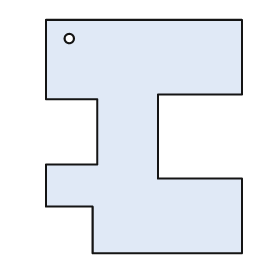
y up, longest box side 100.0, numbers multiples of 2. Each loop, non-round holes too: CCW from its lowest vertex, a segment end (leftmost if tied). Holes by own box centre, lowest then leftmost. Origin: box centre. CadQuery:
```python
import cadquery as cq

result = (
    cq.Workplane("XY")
    .moveTo(-22.0, -50.0)
    .lineTo(42.0, -50.0)
    .lineTo(42.0, -18.0)
    .lineTo(6.0, -18.0)
    .lineTo(6.0, 18.0)
    .lineTo(42.0, 18.0)
    .lineTo(42.0, 50.0)
    .lineTo(-42.0, 50.0)
    .lineTo(-42.0, 16.0)
    .lineTo(-20.0, 16.0)
    .lineTo(-20.0, -12.0)
    .lineTo(-42.0, -12.0)
    .lineTo(-42.0, -30.0)
    .lineTo(-22.0, -30.0)
    .close()
    .moveTo(-32.0, 42.0)
    .circle(2.0)
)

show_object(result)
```